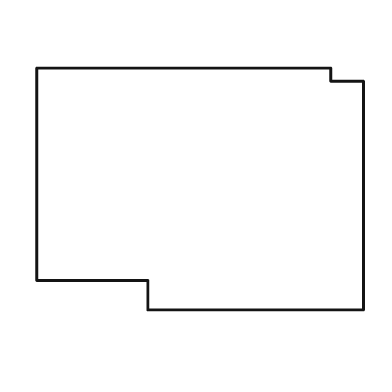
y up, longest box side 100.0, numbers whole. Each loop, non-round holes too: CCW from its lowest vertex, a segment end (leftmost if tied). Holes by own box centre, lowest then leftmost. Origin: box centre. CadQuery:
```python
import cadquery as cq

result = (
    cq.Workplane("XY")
    .moveTo(-16.0, -37.0)
    .lineTo(50.0, -37.0)
    .lineTo(50.0, 33.0)
    .lineTo(40.0, 33.0)
    .lineTo(40.0, 37.0)
    .lineTo(-50.0, 37.0)
    .lineTo(-50.0, -28.0)
    .lineTo(-16.0, -28.0)
    .close()
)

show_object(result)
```